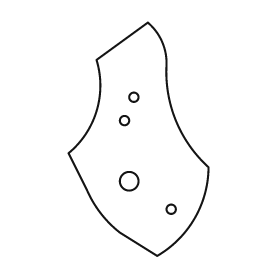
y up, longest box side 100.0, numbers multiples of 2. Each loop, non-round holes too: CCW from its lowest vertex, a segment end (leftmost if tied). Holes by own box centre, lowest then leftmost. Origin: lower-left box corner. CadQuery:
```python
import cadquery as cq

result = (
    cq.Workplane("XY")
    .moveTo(38.0, 0.0)
    .threePointArc((54.0, 16.0), (60.0, 38.0))
    .threePointArc((46.0, 58.0), (42.0, 82.0))
    .threePointArc((40.0, 92.0), (34.0, 100.0))
    .lineTo(12.0, 84.0)
    .threePointArc((12.0, 62.0), (0.0, 44.0))
    .lineTo(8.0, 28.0)
    .threePointArc((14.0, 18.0), (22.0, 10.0))
    .close()
    .moveTo(44.0, 20.0)
    .circle(2.0)
    .moveTo(26.0, 32.0)
    .circle(4.0)
    .moveTo(24.0, 58.0)
    .circle(2.0)
    .moveTo(28.0, 68.0)
    .circle(2.0)
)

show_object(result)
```